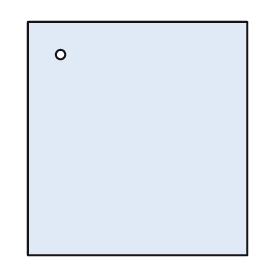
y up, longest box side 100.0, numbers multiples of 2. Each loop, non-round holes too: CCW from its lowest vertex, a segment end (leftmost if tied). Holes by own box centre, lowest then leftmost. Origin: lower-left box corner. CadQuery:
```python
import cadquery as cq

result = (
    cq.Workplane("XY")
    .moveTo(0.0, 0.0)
    .lineTo(94.0, 0.0)
    .lineTo(94.0, 100.0)
    .lineTo(0.0, 100.0)
    .close()
    .moveTo(14.0, 86.0)
    .circle(2.0)
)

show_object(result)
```